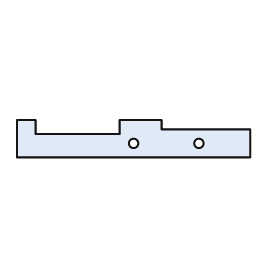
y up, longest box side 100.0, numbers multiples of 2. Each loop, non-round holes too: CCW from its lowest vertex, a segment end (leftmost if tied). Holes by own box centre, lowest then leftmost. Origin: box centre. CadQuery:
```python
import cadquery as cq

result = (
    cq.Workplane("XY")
    .moveTo(-50.0, -8.0)
    .lineTo(50.0, -8.0)
    .lineTo(50.0, 4.0)
    .lineTo(12.0, 4.0)
    .lineTo(12.0, 8.0)
    .lineTo(-6.0, 8.0)
    .lineTo(-6.0, 2.0)
    .lineTo(-42.0, 2.0)
    .lineTo(-42.0, 8.0)
    .lineTo(-50.0, 8.0)
    .close()
    .moveTo(0.0, -2.0)
    .circle(2.0)
    .moveTo(28.0, -2.0)
    .circle(2.0)
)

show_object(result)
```